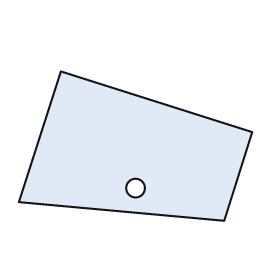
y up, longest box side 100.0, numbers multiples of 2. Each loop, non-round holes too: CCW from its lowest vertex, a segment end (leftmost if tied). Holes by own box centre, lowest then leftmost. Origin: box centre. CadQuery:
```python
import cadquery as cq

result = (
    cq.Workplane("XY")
    .moveTo(38.0, -32.0)
    .lineTo(50.0, 6.0)
    .lineTo(-32.0, 32.0)
    .lineTo(-50.0, -24.0)
    .close()
    .moveTo(0.0, -18.0)
    .circle(4.0)
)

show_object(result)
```